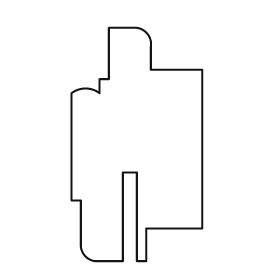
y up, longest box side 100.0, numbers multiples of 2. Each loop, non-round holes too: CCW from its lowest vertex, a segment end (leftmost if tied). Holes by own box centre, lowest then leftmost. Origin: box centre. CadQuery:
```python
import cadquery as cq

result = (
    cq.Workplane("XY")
    .moveTo(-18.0, -50.0)
    .lineTo(-6.0, -50.0)
    .lineTo(-6.0, -12.0)
    .lineTo(0.0, -12.0)
    .lineTo(0.0, -50.0)
    .lineTo(4.0, -50.0)
    .lineTo(4.0, -36.0)
    .lineTo(28.0, -36.0)
    .lineTo(28.0, 32.0)
    .lineTo(6.0, 32.0)
    .lineTo(6.0, 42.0)
    .threePointArc((4.0, 48.0), (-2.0, 50.0))
    .lineTo(-12.0, 50.0)
    .lineTo(-12.0, 28.0)
    .lineTo(-16.0, 28.0)
    .lineTo(-16.0, 22.0)
    .threePointArc((-22.0, 24.0), (-28.0, 22.0))
    .lineTo(-28.0, -24.0)
    .lineTo(-24.0, -24.0)
    .lineTo(-24.0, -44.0)
    .threePointArc((-22.0, -48.0), (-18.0, -50.0))
    .close()
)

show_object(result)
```